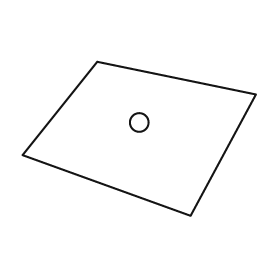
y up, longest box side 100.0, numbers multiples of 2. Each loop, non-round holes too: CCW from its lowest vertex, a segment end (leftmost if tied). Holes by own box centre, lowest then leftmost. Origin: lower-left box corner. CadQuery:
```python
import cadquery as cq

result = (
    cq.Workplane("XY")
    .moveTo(72.0, 0.0)
    .lineTo(100.0, 52.0)
    .lineTo(32.0, 66.0)
    .lineTo(0.0, 26.0)
    .close()
    .moveTo(50.0, 40.0)
    .circle(4.0)
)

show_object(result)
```